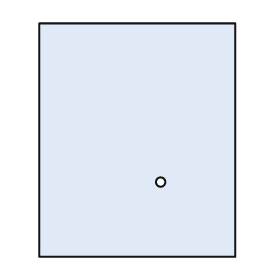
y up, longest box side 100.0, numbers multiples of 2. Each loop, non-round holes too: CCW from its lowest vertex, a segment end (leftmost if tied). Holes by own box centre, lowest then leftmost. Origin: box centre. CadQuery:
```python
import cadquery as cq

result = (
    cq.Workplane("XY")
    .moveTo(-42.0, -50.0)
    .lineTo(42.0, -50.0)
    .lineTo(42.0, 50.0)
    .lineTo(-42.0, 50.0)
    .close()
    .moveTo(10.0, -18.0)
    .circle(2.0)
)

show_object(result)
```